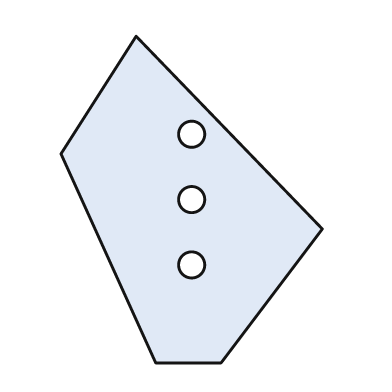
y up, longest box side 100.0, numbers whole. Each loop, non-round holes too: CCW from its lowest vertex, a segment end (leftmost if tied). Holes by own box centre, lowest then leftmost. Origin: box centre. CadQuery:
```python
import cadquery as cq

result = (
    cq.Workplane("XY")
    .moveTo(-11.0, -50.0)
    .lineTo(9.0, -50.0)
    .lineTo(40.0, -9.0)
    .lineTo(-17.0, 50.0)
    .lineTo(-40.0, 14.0)
    .close()
    .moveTo(0.0, -20.0)
    .circle(4.0)
    .moveTo(0.0, 0.0)
    .circle(4.0)
    .moveTo(0.0, 20.0)
    .circle(4.0)
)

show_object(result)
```